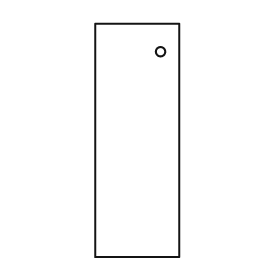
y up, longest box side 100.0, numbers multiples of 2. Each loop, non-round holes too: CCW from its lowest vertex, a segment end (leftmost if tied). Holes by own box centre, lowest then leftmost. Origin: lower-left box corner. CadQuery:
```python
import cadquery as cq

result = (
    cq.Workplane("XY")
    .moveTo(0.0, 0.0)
    .lineTo(36.0, 0.0)
    .lineTo(36.0, 100.0)
    .lineTo(0.0, 100.0)
    .close()
    .moveTo(28.0, 88.0)
    .circle(2.0)
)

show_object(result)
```